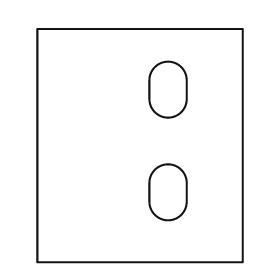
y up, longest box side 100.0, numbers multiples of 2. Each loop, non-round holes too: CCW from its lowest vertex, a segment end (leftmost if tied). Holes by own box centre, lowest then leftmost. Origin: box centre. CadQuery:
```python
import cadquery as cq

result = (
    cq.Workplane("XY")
    .moveTo(-44.0, -50.0)
    .lineTo(44.0, -50.0)
    .lineTo(44.0, 50.0)
    .lineTo(-44.0, 50.0)
    .close()
    .moveTo(4.0, -24.0)
    .threePointArc((12.0, -32.0), (20.0, -24.0))
    .lineTo(20.0, -16.0)
    .threePointArc((12.0, -8.0), (4.0, -16.0))
    .close()
    .moveTo(4.0, 20.0)
    .threePointArc((12.0, 12.0), (20.0, 20.0))
    .lineTo(20.0, 28.0)
    .threePointArc((12.0, 36.0), (4.0, 28.0))
    .close()
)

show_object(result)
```